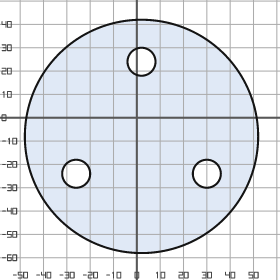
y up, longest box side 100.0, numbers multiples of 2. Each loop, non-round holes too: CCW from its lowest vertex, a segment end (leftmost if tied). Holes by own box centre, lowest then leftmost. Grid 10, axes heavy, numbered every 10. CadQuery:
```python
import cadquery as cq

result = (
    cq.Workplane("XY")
    .moveTo(2.0, -8.0)
    .circle(50.0)
    .moveTo(-26.0, -24.0)
    .circle(6.0)
    .moveTo(30.0, -24.0)
    .circle(6.0)
    .moveTo(2.0, 24.0)
    .circle(6.0)
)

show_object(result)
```